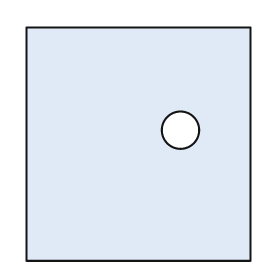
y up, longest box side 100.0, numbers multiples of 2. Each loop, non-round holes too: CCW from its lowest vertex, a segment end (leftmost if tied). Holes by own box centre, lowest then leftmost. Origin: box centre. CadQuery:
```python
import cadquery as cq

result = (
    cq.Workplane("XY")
    .moveTo(-48.0, -50.0)
    .lineTo(48.0, -50.0)
    .lineTo(48.0, 50.0)
    .lineTo(-48.0, 50.0)
    .close()
    .moveTo(18.0, 6.0)
    .circle(8.0)
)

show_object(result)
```